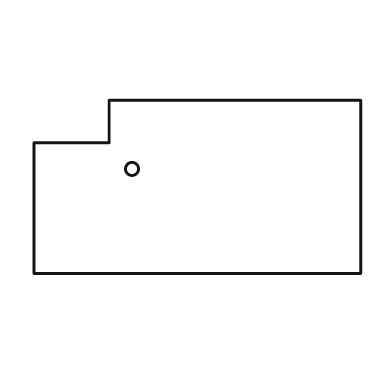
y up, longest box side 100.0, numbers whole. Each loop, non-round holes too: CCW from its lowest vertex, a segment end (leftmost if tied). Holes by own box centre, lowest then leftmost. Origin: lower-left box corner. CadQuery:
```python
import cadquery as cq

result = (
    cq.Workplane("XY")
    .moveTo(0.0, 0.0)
    .lineTo(100.0, 0.0)
    .lineTo(100.0, 53.0)
    .lineTo(23.0, 53.0)
    .lineTo(23.0, 40.0)
    .lineTo(0.0, 40.0)
    .close()
    .moveTo(30.0, 32.0)
    .circle(2.0)
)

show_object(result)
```